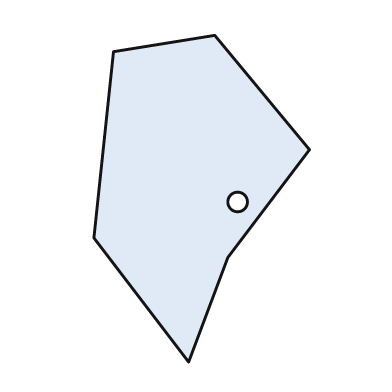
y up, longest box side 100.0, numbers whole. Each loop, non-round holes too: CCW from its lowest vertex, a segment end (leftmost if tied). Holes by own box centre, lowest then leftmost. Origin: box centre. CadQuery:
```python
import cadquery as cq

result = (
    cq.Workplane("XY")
    .moveTo(-4.0, -50.0)
    .lineTo(8.0, -18.0)
    .lineTo(33.0, 15.0)
    .lineTo(4.0, 50.0)
    .lineTo(-27.0, 45.0)
    .lineTo(-33.0, -12.0)
    .close()
    .moveTo(11.0, -1.0)
    .circle(3.0)
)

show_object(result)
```